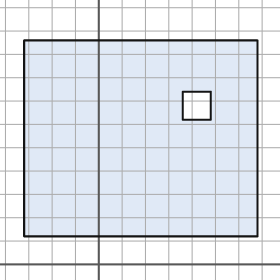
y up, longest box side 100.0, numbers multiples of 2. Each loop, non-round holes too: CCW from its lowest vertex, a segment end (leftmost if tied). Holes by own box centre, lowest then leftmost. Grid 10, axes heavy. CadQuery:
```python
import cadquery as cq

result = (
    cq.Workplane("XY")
    .moveTo(-32.0, 12.0)
    .lineTo(68.0, 12.0)
    .lineTo(68.0, 96.0)
    .lineTo(-32.0, 96.0)
    .close()
    .moveTo(36.0, 62.0)
    .lineTo(48.0, 62.0)
    .lineTo(48.0, 74.0)
    .lineTo(36.0, 74.0)
    .close()
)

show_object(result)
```